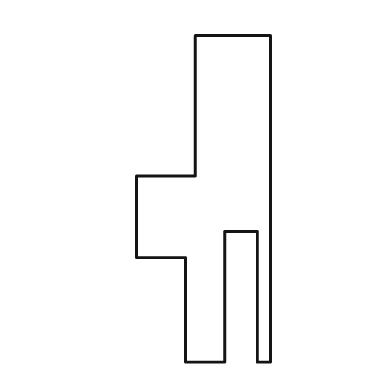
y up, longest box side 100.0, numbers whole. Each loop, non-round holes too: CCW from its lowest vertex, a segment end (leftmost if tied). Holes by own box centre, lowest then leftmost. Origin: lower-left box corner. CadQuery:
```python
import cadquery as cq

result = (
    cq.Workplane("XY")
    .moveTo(15.0, 0.0)
    .lineTo(27.0, 0.0)
    .lineTo(27.0, 40.0)
    .lineTo(37.0, 40.0)
    .lineTo(37.0, 0.0)
    .lineTo(41.0, 0.0)
    .lineTo(41.0, 100.0)
    .lineTo(18.0, 100.0)
    .lineTo(18.0, 57.0)
    .lineTo(0.0, 57.0)
    .lineTo(0.0, 32.0)
    .lineTo(15.0, 32.0)
    .close()
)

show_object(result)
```